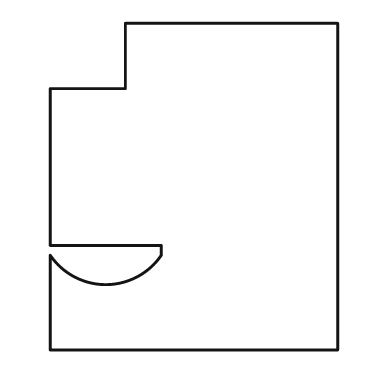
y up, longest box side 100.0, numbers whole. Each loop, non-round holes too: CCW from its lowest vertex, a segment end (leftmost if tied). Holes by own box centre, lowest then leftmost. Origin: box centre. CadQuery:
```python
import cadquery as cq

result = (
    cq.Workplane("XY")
    .moveTo(-44.0, -50.0)
    .lineTo(44.0, -50.0)
    .lineTo(44.0, 50.0)
    .lineTo(-21.0, 50.0)
    .lineTo(-21.0, 30.0)
    .lineTo(-44.0, 30.0)
    .lineTo(-44.0, -18.0)
    .lineTo(-10.0, -18.0)
    .lineTo(-10.0, -21.0)
    .threePointArc((-27.0, -30.0), (-44.0, -21.0))
    .close()
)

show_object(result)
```